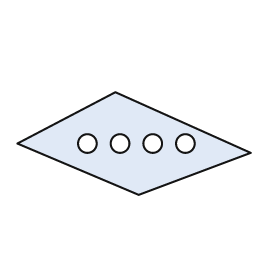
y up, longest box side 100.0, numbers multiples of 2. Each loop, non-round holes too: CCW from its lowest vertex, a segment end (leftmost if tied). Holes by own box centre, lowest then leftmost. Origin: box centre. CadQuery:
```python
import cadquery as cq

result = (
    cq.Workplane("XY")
    .moveTo(2.0, -22.0)
    .lineTo(50.0, -4.0)
    .lineTo(-8.0, 22.0)
    .lineTo(-50.0, 0.0)
    .close()
    .moveTo(-20.0, 0.0)
    .circle(4.0)
    .moveTo(-6.0, 0.0)
    .circle(4.0)
    .moveTo(8.0, 0.0)
    .circle(4.0)
    .moveTo(22.0, 0.0)
    .circle(4.0)
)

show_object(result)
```